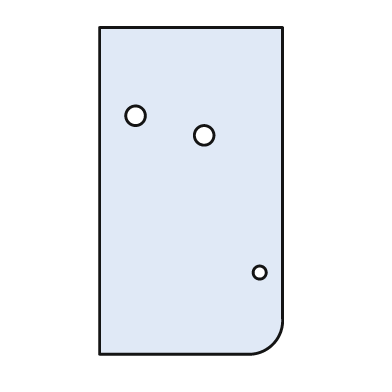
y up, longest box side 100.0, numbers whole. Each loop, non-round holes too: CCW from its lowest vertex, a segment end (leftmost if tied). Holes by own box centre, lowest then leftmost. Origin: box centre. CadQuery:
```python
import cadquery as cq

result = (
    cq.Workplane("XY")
    .moveTo(-28.0, -50.0)
    .lineTo(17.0, -50.0)
    .threePointArc((25.0, -47.0), (28.0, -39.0))
    .lineTo(28.0, 50.0)
    .lineTo(-28.0, 50.0)
    .close()
    .moveTo(21.0, -25.0)
    .circle(2.0)
    .moveTo(4.0, 17.0)
    .circle(3.0)
    .moveTo(-17.0, 23.0)
    .circle(3.0)
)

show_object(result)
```